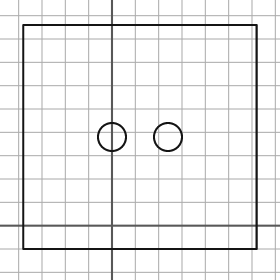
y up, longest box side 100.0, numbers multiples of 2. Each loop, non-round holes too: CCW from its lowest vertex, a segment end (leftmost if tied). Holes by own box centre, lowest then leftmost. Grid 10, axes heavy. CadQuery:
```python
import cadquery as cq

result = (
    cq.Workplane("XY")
    .moveTo(-38.0, -10.0)
    .lineTo(62.0, -10.0)
    .lineTo(62.0, 86.0)
    .lineTo(-38.0, 86.0)
    .close()
    .moveTo(0.0, 38.0)
    .circle(6.0)
    .moveTo(24.0, 38.0)
    .circle(6.0)
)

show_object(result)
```